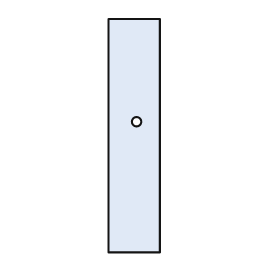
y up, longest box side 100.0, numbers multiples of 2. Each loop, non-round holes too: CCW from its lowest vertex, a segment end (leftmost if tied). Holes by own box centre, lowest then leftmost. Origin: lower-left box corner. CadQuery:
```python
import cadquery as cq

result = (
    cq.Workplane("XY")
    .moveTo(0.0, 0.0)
    .lineTo(22.0, 0.0)
    .lineTo(22.0, 100.0)
    .lineTo(0.0, 100.0)
    .close()
    .moveTo(12.0, 56.0)
    .circle(2.0)
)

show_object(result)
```